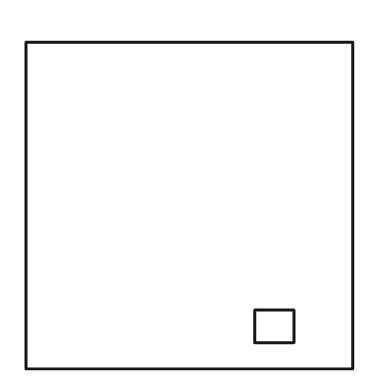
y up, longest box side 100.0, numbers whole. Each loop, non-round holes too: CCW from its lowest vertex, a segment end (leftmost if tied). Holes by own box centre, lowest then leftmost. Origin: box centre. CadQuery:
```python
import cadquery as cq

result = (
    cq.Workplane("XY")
    .moveTo(-50.0, -50.0)
    .lineTo(50.0, -50.0)
    .lineTo(50.0, 50.0)
    .lineTo(-50.0, 50.0)
    .close()
    .moveTo(20.0, -42.0)
    .lineTo(32.0, -42.0)
    .lineTo(32.0, -32.0)
    .lineTo(20.0, -32.0)
    .close()
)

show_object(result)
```